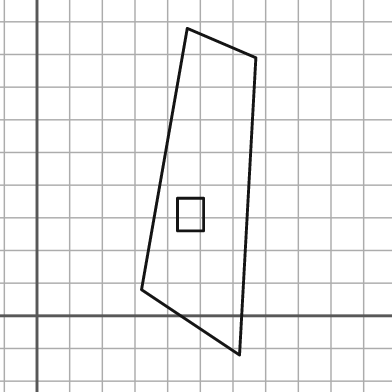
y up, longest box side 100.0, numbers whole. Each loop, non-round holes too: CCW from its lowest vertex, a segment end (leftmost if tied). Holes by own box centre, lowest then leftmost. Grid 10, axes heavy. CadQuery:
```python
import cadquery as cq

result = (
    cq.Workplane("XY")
    .moveTo(62.0, -12.0)
    .lineTo(67.0, 79.0)
    .lineTo(46.0, 88.0)
    .lineTo(32.0, 8.0)
    .close()
    .moveTo(43.0, 26.0)
    .lineTo(51.0, 26.0)
    .lineTo(51.0, 36.0)
    .lineTo(43.0, 36.0)
    .close()
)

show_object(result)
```